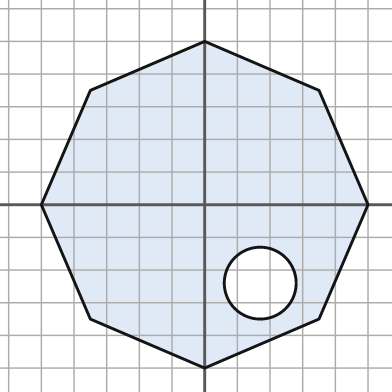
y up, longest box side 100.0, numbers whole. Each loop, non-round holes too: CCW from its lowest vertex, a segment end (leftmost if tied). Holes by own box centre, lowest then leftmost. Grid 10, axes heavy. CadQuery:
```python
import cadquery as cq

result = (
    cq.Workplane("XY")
    .moveTo(0.0, -50.0)
    .lineTo(35.0, -35.0)
    .lineTo(50.0, 0.0)
    .lineTo(35.0, 35.0)
    .lineTo(0.0, 50.0)
    .lineTo(-35.0, 35.0)
    .lineTo(-50.0, 0.0)
    .lineTo(-35.0, -35.0)
    .close()
    .moveTo(17.0, -24.0)
    .circle(11.0)
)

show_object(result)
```